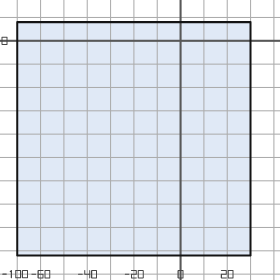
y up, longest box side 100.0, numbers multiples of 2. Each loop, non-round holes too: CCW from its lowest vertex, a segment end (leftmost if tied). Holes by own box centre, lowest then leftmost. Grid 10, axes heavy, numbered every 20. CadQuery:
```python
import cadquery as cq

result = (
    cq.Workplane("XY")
    .moveTo(-70.0, -92.0)
    .lineTo(30.0, -92.0)
    .lineTo(30.0, 8.0)
    .lineTo(-70.0, 8.0)
    .close()
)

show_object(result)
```